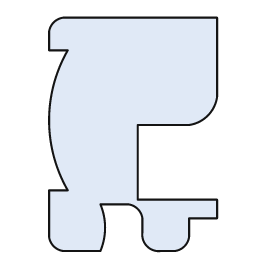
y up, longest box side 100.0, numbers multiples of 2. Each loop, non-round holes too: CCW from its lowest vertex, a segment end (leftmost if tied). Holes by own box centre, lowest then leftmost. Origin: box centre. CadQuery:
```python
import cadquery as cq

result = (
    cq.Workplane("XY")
    .moveTo(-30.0, -50.0)
    .lineTo(-14.0, -50.0)
    .threePointArc((-12.0, -40.0), (-14.0, -30.0))
    .lineTo(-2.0, -30.0)
    .threePointArc((2.0, -32.0), (4.0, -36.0))
    .lineTo(4.0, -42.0)
    .threePointArc((6.0, -48.0), (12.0, -50.0))
    .lineTo(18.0, -50.0)
    .threePointArc((22.0, -48.0), (24.0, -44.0))
    .lineTo(24.0, -36.0)
    .lineTo(36.0, -36.0)
    .lineTo(36.0, -28.0)
    .lineTo(2.0, -28.0)
    .lineTo(2.0, 4.0)
    .lineTo(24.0, 4.0)
    .threePointArc((32.0, 8.0), (36.0, 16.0))
    .lineTo(36.0, 50.0)
    .lineTo(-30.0, 50.0)
    .threePointArc((-34.0, 48.0), (-36.0, 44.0))
    .lineTo(-36.0, 36.0)
    .lineTo(-28.0, 36.0)
    .threePointArc((-36.0, 6.0), (-28.0, -24.0))
    .lineTo(-36.0, -24.0)
    .lineTo(-36.0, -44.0)
    .threePointArc((-34.0, -48.0), (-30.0, -50.0))
    .close()
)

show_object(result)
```